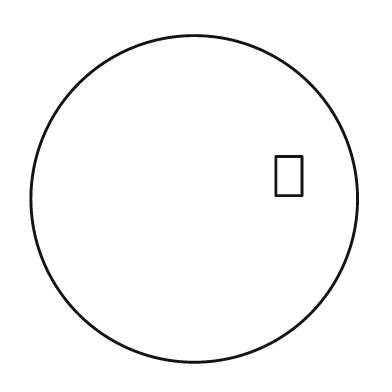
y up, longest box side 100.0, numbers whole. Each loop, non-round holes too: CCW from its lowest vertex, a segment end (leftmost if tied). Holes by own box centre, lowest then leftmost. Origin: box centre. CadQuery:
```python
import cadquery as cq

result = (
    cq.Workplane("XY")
    .moveTo(0.0, 0.0)
    .circle(50.0)
    .moveTo(25.0, 1.0)
    .lineTo(33.0, 1.0)
    .lineTo(33.0, 13.0)
    .lineTo(25.0, 13.0)
    .close()
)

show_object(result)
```